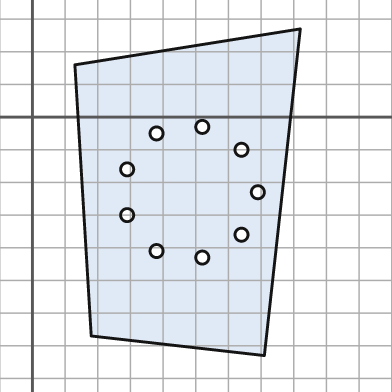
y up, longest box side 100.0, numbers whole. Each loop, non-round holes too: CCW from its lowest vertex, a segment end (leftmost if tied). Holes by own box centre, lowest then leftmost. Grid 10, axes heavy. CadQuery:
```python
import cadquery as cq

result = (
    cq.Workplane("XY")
    .moveTo(71.0, -73.0)
    .lineTo(82.0, 27.0)
    .lineTo(13.0, 16.0)
    .lineTo(18.0, -67.0)
    .close()
    .moveTo(52.0, -43.0)
    .circle(2.0)
    .moveTo(38.0, -41.0)
    .circle(2.0)
    .moveTo(64.0, -36.0)
    .circle(2.0)
    .moveTo(29.0, -30.0)
    .circle(2.0)
    .moveTo(69.0, -23.0)
    .circle(2.0)
    .moveTo(29.0, -16.0)
    .circle(2.0)
    .moveTo(64.0, -10.0)
    .circle(2.0)
    .moveTo(38.0, -5.0)
    .circle(2.0)
    .moveTo(52.0, -3.0)
    .circle(2.0)
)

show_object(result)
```